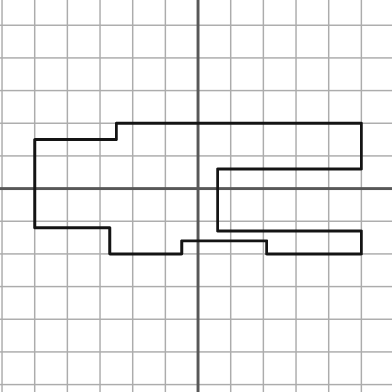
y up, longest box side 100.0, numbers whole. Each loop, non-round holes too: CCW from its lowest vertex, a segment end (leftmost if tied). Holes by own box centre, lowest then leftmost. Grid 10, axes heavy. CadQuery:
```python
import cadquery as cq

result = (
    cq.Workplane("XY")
    .moveTo(-27.0, -20.0)
    .lineTo(-5.0, -20.0)
    .lineTo(-5.0, -16.0)
    .lineTo(21.0, -16.0)
    .lineTo(21.0, -20.0)
    .lineTo(50.0, -20.0)
    .lineTo(50.0, -13.0)
    .lineTo(6.0, -13.0)
    .lineTo(6.0, 6.0)
    .lineTo(50.0, 6.0)
    .lineTo(50.0, 20.0)
    .lineTo(-25.0, 20.0)
    .lineTo(-25.0, 15.0)
    .lineTo(-50.0, 15.0)
    .lineTo(-50.0, -12.0)
    .lineTo(-27.0, -12.0)
    .close()
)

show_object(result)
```